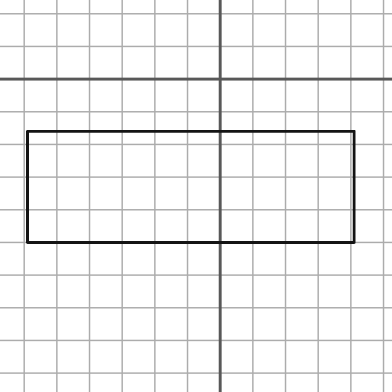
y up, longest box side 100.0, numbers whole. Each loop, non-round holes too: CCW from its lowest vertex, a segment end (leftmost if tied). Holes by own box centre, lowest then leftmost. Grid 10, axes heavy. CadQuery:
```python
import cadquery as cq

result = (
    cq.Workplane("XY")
    .moveTo(-59.0, -50.0)
    .lineTo(41.0, -50.0)
    .lineTo(41.0, -16.0)
    .lineTo(-59.0, -16.0)
    .close()
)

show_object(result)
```